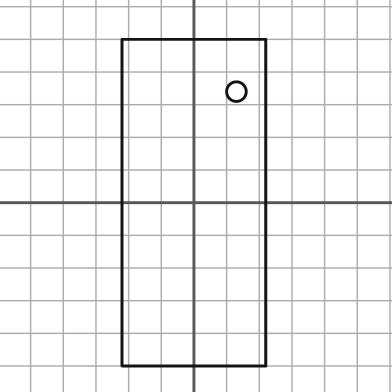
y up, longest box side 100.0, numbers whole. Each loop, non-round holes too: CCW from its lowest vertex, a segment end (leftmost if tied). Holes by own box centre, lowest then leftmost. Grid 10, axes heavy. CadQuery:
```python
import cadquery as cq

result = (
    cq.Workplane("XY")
    .moveTo(-22.0, -50.0)
    .lineTo(22.0, -50.0)
    .lineTo(22.0, 50.0)
    .lineTo(-22.0, 50.0)
    .close()
    .moveTo(13.0, 34.0)
    .circle(3.0)
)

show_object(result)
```